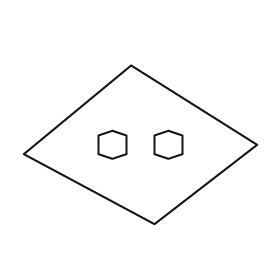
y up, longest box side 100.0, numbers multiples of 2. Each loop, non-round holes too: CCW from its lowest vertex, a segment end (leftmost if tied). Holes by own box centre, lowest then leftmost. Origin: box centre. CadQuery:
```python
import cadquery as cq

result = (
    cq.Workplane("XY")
    .moveTo(6.0, -34.0)
    .lineTo(50.0, 0.0)
    .lineTo(-4.0, 34.0)
    .lineTo(-50.0, -4.0)
    .close()
    .moveTo(-12.0, -6.0)
    .lineTo(-6.0, -4.0)
    .lineTo(-6.0, 4.0)
    .lineTo(-12.0, 6.0)
    .lineTo(-18.0, 4.0)
    .lineTo(-18.0, -4.0)
    .close()
    .moveTo(12.0, -6.0)
    .lineTo(18.0, -4.0)
    .lineTo(18.0, 4.0)
    .lineTo(12.0, 6.0)
    .lineTo(6.0, 4.0)
    .lineTo(6.0, -4.0)
    .close()
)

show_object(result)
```